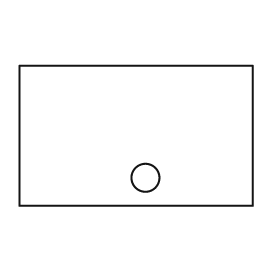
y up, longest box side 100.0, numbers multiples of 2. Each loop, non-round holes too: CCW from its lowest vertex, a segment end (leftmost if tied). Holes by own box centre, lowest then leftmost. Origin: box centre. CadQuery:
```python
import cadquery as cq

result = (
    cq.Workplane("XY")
    .moveTo(-50.0, -30.0)
    .lineTo(50.0, -30.0)
    .lineTo(50.0, 30.0)
    .lineTo(-50.0, 30.0)
    .close()
    .moveTo(4.0, -18.0)
    .circle(6.0)
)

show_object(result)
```